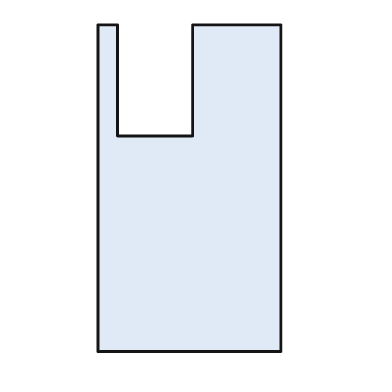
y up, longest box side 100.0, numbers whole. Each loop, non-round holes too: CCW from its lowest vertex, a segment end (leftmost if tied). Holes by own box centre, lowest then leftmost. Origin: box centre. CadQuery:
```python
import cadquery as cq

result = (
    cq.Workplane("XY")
    .moveTo(-28.0, -50.0)
    .lineTo(28.0, -50.0)
    .lineTo(28.0, 50.0)
    .lineTo(1.0, 50.0)
    .lineTo(1.0, 16.0)
    .lineTo(-22.0, 16.0)
    .lineTo(-22.0, 50.0)
    .lineTo(-28.0, 50.0)
    .close()
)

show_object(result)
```